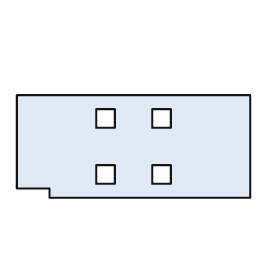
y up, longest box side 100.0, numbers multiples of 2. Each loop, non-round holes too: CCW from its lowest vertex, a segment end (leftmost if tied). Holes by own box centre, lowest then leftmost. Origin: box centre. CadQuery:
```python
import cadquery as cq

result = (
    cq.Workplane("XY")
    .moveTo(-36.0, -22.0)
    .lineTo(50.0, -22.0)
    .lineTo(50.0, 22.0)
    .lineTo(-50.0, 22.0)
    .lineTo(-50.0, -18.0)
    .lineTo(-36.0, -18.0)
    .close()
    .moveTo(-16.0, -16.0)
    .lineTo(-8.0, -16.0)
    .lineTo(-8.0, -8.0)
    .lineTo(-16.0, -8.0)
    .close()
    .moveTo(8.0, -16.0)
    .lineTo(16.0, -16.0)
    .lineTo(16.0, -8.0)
    .lineTo(8.0, -8.0)
    .close()
    .moveTo(-16.0, 8.0)
    .lineTo(-8.0, 8.0)
    .lineTo(-8.0, 16.0)
    .lineTo(-16.0, 16.0)
    .close()
    .moveTo(8.0, 8.0)
    .lineTo(16.0, 8.0)
    .lineTo(16.0, 16.0)
    .lineTo(8.0, 16.0)
    .close()
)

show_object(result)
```